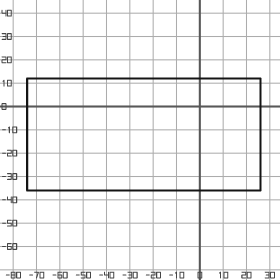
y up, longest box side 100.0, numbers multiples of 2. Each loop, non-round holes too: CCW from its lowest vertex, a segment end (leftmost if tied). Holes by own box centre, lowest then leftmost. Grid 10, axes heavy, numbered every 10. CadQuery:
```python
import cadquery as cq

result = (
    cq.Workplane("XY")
    .moveTo(-74.0, -36.0)
    .lineTo(26.0, -36.0)
    .lineTo(26.0, 12.0)
    .lineTo(-74.0, 12.0)
    .close()
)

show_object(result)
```